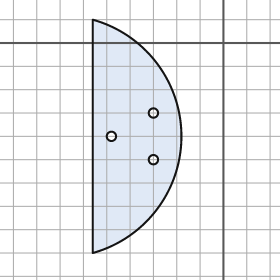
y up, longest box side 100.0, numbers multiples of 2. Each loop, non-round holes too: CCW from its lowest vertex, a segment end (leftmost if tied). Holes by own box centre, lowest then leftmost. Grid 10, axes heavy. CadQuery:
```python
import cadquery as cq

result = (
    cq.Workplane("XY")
    .moveTo(-56.0, -90.0)
    .threePointArc((-18.0, -40.0), (-56.0, 10.0))
    .close()
    .moveTo(-30.0, -50.0)
    .circle(2.0)
    .moveTo(-48.0, -40.0)
    .circle(2.0)
    .moveTo(-30.0, -30.0)
    .circle(2.0)
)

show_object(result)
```